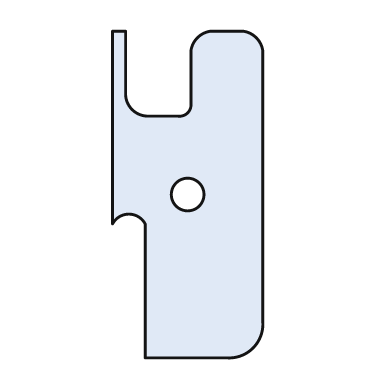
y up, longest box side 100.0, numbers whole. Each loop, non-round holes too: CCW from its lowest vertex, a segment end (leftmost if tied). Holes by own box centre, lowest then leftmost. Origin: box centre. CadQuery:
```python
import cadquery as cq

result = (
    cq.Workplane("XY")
    .moveTo(-13.0, -50.0)
    .lineTo(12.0, -50.0)
    .threePointArc((20.0, -47.0), (23.0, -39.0))
    .lineTo(23.0, 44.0)
    .threePointArc((21.0, 48.0), (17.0, 50.0))
    .lineTo(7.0, 50.0)
    .threePointArc((3.0, 48.0), (1.0, 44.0))
    .lineTo(1.0, 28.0)
    .threePointArc((0.0, 25.0), (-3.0, 24.0))
    .lineTo(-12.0, 24.0)
    .threePointArc((-17.0, 26.0), (-19.0, 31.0))
    .lineTo(-19.0, 50.0)
    .lineTo(-23.0, 50.0)
    .lineTo(-23.0, -9.0)
    .threePointArc((-18.0, -6.0), (-13.0, -9.0))
    .close()
    .moveTo(0.0, 0.0)
    .circle(5.0)
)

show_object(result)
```